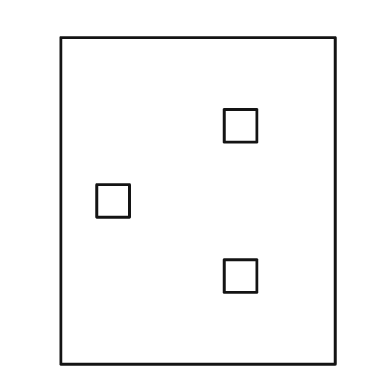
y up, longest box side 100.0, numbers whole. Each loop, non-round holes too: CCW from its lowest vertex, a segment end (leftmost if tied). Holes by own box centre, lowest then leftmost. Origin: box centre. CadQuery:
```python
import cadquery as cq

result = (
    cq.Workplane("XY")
    .moveTo(-42.0, -50.0)
    .lineTo(42.0, -50.0)
    .lineTo(42.0, 50.0)
    .lineTo(-42.0, 50.0)
    .close()
    .moveTo(8.0, -28.0)
    .lineTo(18.0, -28.0)
    .lineTo(18.0, -18.0)
    .lineTo(8.0, -18.0)
    .close()
    .moveTo(-31.0, -5.0)
    .lineTo(-21.0, -5.0)
    .lineTo(-21.0, 5.0)
    .lineTo(-31.0, 5.0)
    .close()
    .moveTo(8.0, 18.0)
    .lineTo(18.0, 18.0)
    .lineTo(18.0, 28.0)
    .lineTo(8.0, 28.0)
    .close()
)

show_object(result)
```